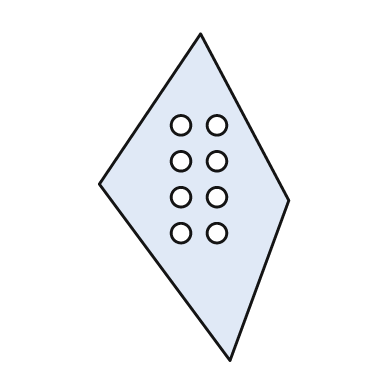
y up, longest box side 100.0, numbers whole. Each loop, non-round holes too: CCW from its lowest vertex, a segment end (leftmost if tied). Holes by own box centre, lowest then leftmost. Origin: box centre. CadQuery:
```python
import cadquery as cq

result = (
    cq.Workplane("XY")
    .moveTo(11.0, -50.0)
    .lineTo(29.0, -1.0)
    .lineTo(2.0, 50.0)
    .lineTo(-29.0, 4.0)
    .close()
    .moveTo(-4.0, -11.0)
    .circle(3.0)
    .moveTo(7.0, -11.0)
    .circle(3.0)
    .moveTo(-4.0, 0.0)
    .circle(3.0)
    .moveTo(7.0, 0.0)
    .circle(3.0)
    .moveTo(-4.0, 11.0)
    .circle(3.0)
    .moveTo(7.0, 11.0)
    .circle(3.0)
    .moveTo(-4.0, 22.0)
    .circle(3.0)
    .moveTo(7.0, 22.0)
    .circle(3.0)
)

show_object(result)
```